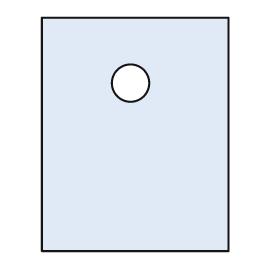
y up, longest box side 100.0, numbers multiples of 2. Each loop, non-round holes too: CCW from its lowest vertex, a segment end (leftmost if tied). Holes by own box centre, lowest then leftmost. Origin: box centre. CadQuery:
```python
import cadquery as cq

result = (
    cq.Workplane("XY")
    .moveTo(-40.0, -50.0)
    .lineTo(40.0, -50.0)
    .lineTo(40.0, 50.0)
    .lineTo(-40.0, 50.0)
    .close()
    .moveTo(-2.0, 22.0)
    .circle(8.0)
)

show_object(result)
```